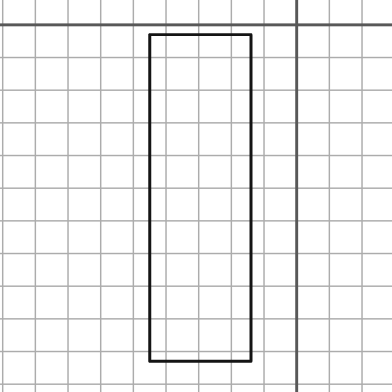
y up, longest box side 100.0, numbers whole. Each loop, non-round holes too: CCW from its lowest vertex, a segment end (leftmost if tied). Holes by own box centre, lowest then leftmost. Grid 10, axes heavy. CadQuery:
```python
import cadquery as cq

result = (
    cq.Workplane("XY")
    .moveTo(-45.0, -103.0)
    .lineTo(-14.0, -103.0)
    .lineTo(-14.0, -3.0)
    .lineTo(-45.0, -3.0)
    .close()
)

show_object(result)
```